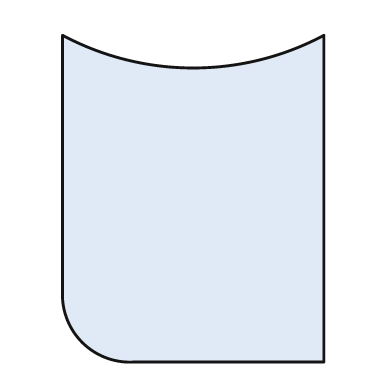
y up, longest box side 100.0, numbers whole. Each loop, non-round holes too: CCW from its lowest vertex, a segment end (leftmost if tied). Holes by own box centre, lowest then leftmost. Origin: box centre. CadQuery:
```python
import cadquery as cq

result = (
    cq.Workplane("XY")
    .moveTo(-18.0, -50.0)
    .lineTo(40.0, -50.0)
    .lineTo(40.0, 50.0)
    .threePointArc((0.0, 40.0), (-40.0, 50.0))
    .lineTo(-40.0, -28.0)
    .threePointArc((-34.0, -44.0), (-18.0, -50.0))
    .close()
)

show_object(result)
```